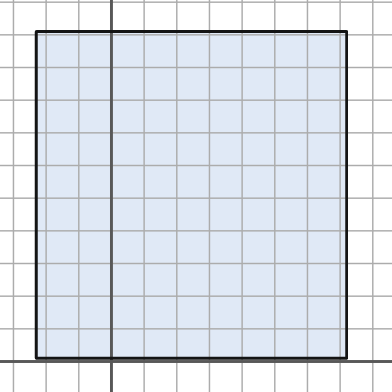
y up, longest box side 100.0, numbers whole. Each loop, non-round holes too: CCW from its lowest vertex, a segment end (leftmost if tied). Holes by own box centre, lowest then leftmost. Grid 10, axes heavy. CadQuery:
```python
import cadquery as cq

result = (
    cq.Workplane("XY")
    .moveTo(-23.0, 1.0)
    .lineTo(72.0, 1.0)
    .lineTo(72.0, 101.0)
    .lineTo(-23.0, 101.0)
    .close()
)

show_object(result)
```